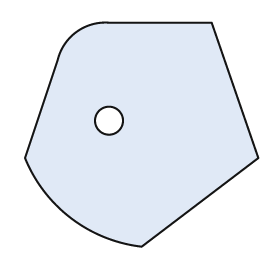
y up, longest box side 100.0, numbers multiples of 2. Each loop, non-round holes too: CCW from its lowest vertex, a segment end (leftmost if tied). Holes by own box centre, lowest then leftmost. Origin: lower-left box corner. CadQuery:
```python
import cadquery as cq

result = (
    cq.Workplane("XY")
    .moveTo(50.0, 0.0)
    .lineTo(100.0, 38.0)
    .lineTo(80.0, 96.0)
    .lineTo(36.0, 96.0)
    .threePointArc((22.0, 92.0), (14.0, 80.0))
    .lineTo(0.0, 38.0)
    .threePointArc((20.0, 12.0), (50.0, 0.0))
    .close()
    .moveTo(36.0, 54.0)
    .circle(6.0)
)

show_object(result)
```